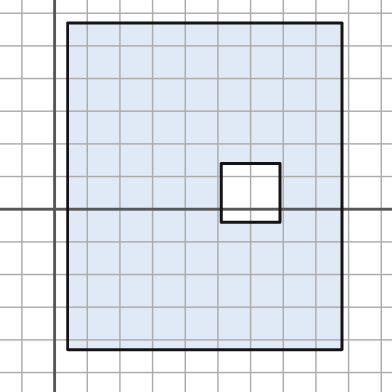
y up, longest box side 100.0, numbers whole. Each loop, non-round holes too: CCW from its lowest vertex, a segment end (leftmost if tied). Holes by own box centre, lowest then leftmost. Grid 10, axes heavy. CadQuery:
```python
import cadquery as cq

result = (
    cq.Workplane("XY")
    .moveTo(4.0, -43.0)
    .lineTo(88.0, -43.0)
    .lineTo(88.0, 57.0)
    .lineTo(4.0, 57.0)
    .close()
    .moveTo(51.0, -4.0)
    .lineTo(69.0, -4.0)
    .lineTo(69.0, 14.0)
    .lineTo(51.0, 14.0)
    .close()
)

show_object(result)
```